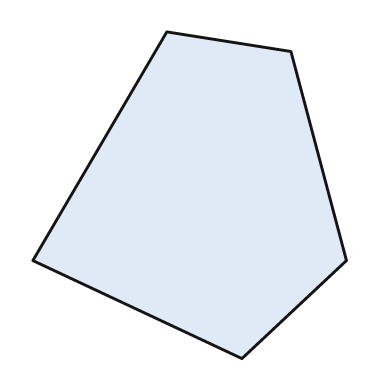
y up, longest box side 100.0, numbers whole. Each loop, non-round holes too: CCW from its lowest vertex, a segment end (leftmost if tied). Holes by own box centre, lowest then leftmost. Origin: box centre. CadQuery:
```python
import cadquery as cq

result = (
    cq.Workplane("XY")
    .moveTo(16.0, -50.0)
    .lineTo(48.0, -20.0)
    .lineTo(31.0, 44.0)
    .lineTo(-7.0, 50.0)
    .lineTo(-48.0, -20.0)
    .close()
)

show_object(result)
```